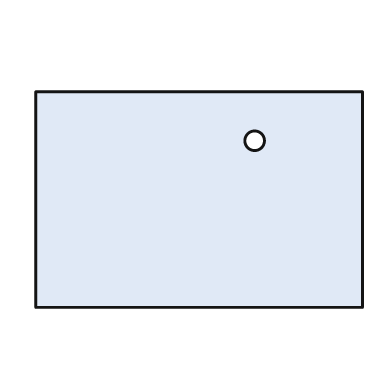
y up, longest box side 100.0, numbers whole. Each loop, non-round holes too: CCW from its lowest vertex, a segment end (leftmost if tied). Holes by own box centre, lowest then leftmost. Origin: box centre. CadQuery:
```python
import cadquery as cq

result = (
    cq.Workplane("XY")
    .moveTo(-50.0, -33.0)
    .lineTo(50.0, -33.0)
    .lineTo(50.0, 33.0)
    .lineTo(-50.0, 33.0)
    .close()
    .moveTo(17.0, 18.0)
    .circle(3.0)
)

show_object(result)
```